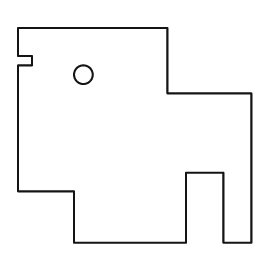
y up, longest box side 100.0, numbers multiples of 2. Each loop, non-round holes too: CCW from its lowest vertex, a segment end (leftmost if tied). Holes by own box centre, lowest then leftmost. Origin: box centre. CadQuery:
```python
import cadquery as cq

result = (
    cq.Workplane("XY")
    .moveTo(-26.0, -46.0)
    .lineTo(22.0, -46.0)
    .lineTo(22.0, -16.0)
    .lineTo(38.0, -16.0)
    .lineTo(38.0, -46.0)
    .lineTo(50.0, -46.0)
    .lineTo(50.0, 18.0)
    .lineTo(14.0, 18.0)
    .lineTo(14.0, 46.0)
    .lineTo(-50.0, 46.0)
    .lineTo(-50.0, 34.0)
    .lineTo(-44.0, 34.0)
    .lineTo(-44.0, 30.0)
    .lineTo(-50.0, 30.0)
    .lineTo(-50.0, -24.0)
    .lineTo(-26.0, -24.0)
    .close()
    .moveTo(-22.0, 26.0)
    .circle(4.0)
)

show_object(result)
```